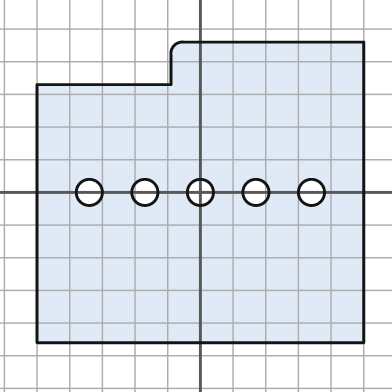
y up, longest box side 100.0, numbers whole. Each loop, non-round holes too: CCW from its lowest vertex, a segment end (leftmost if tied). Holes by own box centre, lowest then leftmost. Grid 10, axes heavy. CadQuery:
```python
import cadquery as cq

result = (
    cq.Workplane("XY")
    .moveTo(-50.0, -46.0)
    .lineTo(50.0, -46.0)
    .lineTo(50.0, 46.0)
    .lineTo(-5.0, 46.0)
    .threePointArc((-8.0, 45.0), (-9.0, 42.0))
    .lineTo(-9.0, 33.0)
    .lineTo(-50.0, 33.0)
    .close()
    .moveTo(-34.0, 0.0)
    .circle(4.0)
    .moveTo(-17.0, 0.0)
    .circle(4.0)
    .moveTo(0.0, 0.0)
    .circle(4.0)
    .moveTo(17.0, 0.0)
    .circle(4.0)
    .moveTo(34.0, 0.0)
    .circle(4.0)
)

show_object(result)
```